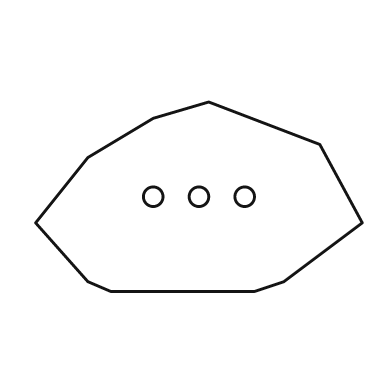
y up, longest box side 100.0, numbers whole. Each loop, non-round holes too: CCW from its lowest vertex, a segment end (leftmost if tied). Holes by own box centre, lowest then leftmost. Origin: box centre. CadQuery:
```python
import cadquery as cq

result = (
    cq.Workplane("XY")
    .moveTo(-27.0, -29.0)
    .lineTo(17.0, -29.0)
    .lineTo(26.0, -26.0)
    .lineTo(50.0, -8.0)
    .lineTo(37.0, 16.0)
    .lineTo(3.0, 29.0)
    .lineTo(-14.0, 24.0)
    .lineTo(-34.0, 12.0)
    .lineTo(-50.0, -8.0)
    .lineTo(-34.0, -26.0)
    .close()
    .moveTo(-14.0, 0.0)
    .circle(3.0)
    .moveTo(0.0, 0.0)
    .circle(3.0)
    .moveTo(14.0, 0.0)
    .circle(3.0)
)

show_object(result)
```